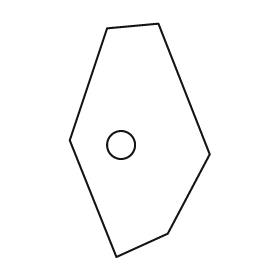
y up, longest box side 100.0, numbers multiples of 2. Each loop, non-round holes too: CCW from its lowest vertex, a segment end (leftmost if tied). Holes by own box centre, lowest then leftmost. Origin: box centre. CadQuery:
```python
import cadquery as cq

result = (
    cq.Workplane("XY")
    .moveTo(-10.0, -50.0)
    .lineTo(12.0, -40.0)
    .lineTo(30.0, -6.0)
    .lineTo(8.0, 50.0)
    .lineTo(-14.0, 48.0)
    .lineTo(-30.0, 0.0)
    .close()
    .moveTo(-8.0, -2.0)
    .circle(6.0)
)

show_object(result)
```